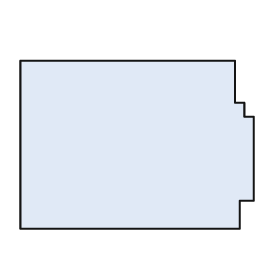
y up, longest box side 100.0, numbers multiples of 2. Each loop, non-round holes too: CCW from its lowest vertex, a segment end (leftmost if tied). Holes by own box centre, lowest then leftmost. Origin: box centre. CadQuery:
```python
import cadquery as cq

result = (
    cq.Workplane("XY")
    .moveTo(-50.0, -36.0)
    .lineTo(44.0, -36.0)
    .lineTo(44.0, -24.0)
    .lineTo(50.0, -24.0)
    .lineTo(50.0, 12.0)
    .lineTo(46.0, 12.0)
    .lineTo(46.0, 18.0)
    .lineTo(42.0, 18.0)
    .lineTo(42.0, 36.0)
    .lineTo(-50.0, 36.0)
    .close()
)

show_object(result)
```